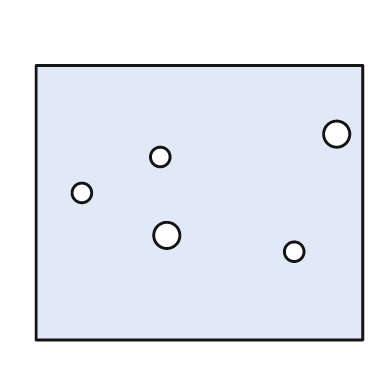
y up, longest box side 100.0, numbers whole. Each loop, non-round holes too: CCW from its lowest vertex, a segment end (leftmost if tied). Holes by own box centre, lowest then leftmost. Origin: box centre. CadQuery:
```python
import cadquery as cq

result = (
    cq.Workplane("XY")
    .moveTo(-50.0, -42.0)
    .lineTo(50.0, -42.0)
    .lineTo(50.0, 42.0)
    .lineTo(-50.0, 42.0)
    .close()
    .moveTo(29.0, -15.0)
    .circle(3.0)
    .moveTo(-10.0, -10.0)
    .circle(4.0)
    .moveTo(-36.0, 3.0)
    .circle(3.0)
    .moveTo(-12.0, 14.0)
    .circle(3.0)
    .moveTo(42.0, 21.0)
    .circle(4.0)
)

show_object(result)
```